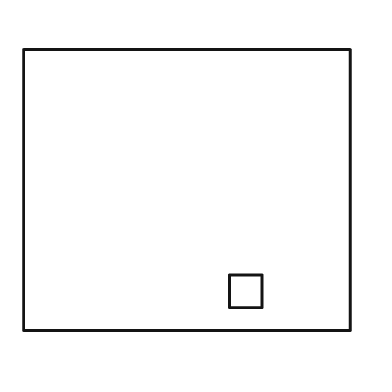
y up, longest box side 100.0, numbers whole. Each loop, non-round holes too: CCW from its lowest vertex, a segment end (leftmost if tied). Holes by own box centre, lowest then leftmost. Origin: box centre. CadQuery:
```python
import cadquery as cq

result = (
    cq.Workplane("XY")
    .moveTo(-50.0, -43.0)
    .lineTo(50.0, -43.0)
    .lineTo(50.0, 43.0)
    .lineTo(-50.0, 43.0)
    .close()
    .moveTo(13.0, -36.0)
    .lineTo(23.0, -36.0)
    .lineTo(23.0, -26.0)
    .lineTo(13.0, -26.0)
    .close()
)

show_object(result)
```